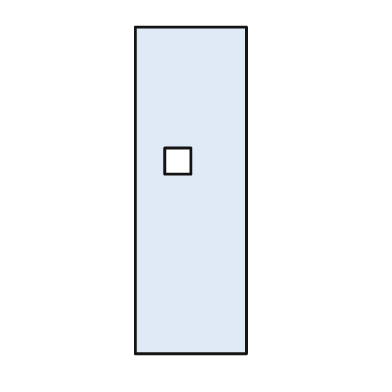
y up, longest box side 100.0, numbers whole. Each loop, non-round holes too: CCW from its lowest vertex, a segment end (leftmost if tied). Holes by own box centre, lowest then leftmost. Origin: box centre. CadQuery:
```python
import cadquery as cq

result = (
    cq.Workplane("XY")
    .moveTo(-17.0, -50.0)
    .lineTo(17.0, -50.0)
    .lineTo(17.0, 50.0)
    .lineTo(-17.0, 50.0)
    .close()
    .moveTo(-8.0, 5.0)
    .lineTo(0.0, 5.0)
    .lineTo(0.0, 13.0)
    .lineTo(-8.0, 13.0)
    .close()
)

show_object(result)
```